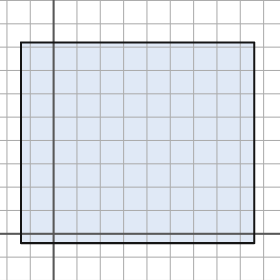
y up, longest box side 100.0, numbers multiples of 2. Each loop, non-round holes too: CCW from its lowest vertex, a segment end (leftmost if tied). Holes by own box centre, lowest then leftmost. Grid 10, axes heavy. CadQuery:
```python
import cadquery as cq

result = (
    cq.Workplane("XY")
    .moveTo(-14.0, -4.0)
    .lineTo(86.0, -4.0)
    .lineTo(86.0, 82.0)
    .lineTo(-14.0, 82.0)
    .close()
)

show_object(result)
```